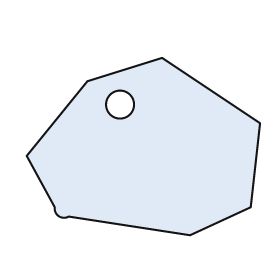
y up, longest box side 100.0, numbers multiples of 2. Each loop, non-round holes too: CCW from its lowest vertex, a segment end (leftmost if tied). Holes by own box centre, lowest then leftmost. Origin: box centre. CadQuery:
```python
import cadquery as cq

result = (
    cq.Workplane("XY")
    .moveTo(20.0, -38.0)
    .lineTo(46.0, -26.0)
    .lineTo(50.0, 10.0)
    .lineTo(8.0, 38.0)
    .lineTo(-24.0, 28.0)
    .lineTo(-50.0, -4.0)
    .lineTo(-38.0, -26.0)
    .threePointArc((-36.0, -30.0), (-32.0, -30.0))
    .close()
    .moveTo(-10.0, 18.0)
    .circle(6.0)
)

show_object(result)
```